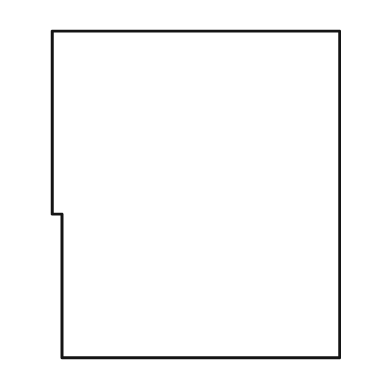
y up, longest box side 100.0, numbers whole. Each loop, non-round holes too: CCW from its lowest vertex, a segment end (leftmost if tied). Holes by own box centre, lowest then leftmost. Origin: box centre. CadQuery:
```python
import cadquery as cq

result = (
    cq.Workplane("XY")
    .moveTo(-41.0, -50.0)
    .lineTo(44.0, -50.0)
    .lineTo(44.0, 50.0)
    .lineTo(-44.0, 50.0)
    .lineTo(-44.0, -6.0)
    .lineTo(-41.0, -6.0)
    .close()
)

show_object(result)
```